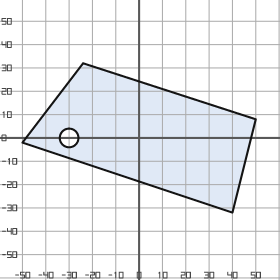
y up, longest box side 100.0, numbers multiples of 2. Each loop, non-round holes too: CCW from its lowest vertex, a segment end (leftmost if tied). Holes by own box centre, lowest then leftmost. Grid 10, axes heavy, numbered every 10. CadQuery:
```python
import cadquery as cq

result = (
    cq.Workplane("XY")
    .moveTo(40.0, -32.0)
    .lineTo(50.0, 8.0)
    .lineTo(-24.0, 32.0)
    .lineTo(-50.0, -2.0)
    .close()
    .moveTo(-30.0, 0.0)
    .circle(4.0)
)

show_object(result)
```